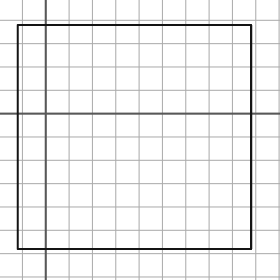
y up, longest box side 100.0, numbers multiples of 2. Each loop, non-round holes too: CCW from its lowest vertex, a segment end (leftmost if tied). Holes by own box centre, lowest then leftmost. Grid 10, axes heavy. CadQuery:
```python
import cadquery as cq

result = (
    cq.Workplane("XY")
    .moveTo(-12.0, -58.0)
    .lineTo(88.0, -58.0)
    .lineTo(88.0, 38.0)
    .lineTo(-12.0, 38.0)
    .close()
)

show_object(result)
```